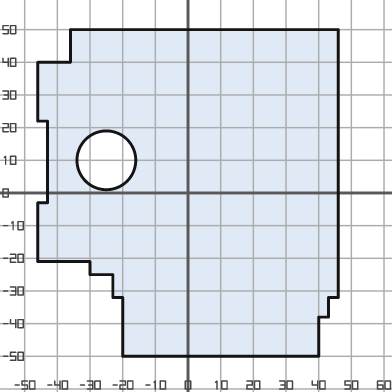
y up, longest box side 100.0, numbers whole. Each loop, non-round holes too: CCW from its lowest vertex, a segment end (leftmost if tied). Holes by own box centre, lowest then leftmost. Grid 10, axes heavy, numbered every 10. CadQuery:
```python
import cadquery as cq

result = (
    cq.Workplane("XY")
    .moveTo(-20.0, -50.0)
    .lineTo(40.0, -50.0)
    .lineTo(40.0, -38.0)
    .lineTo(43.0, -38.0)
    .lineTo(43.0, -32.0)
    .lineTo(46.0, -32.0)
    .lineTo(46.0, 50.0)
    .lineTo(-36.0, 50.0)
    .lineTo(-36.0, 40.0)
    .lineTo(-46.0, 40.0)
    .lineTo(-46.0, 22.0)
    .lineTo(-43.0, 22.0)
    .lineTo(-43.0, -3.0)
    .lineTo(-46.0, -3.0)
    .lineTo(-46.0, -21.0)
    .lineTo(-30.0, -21.0)
    .lineTo(-30.0, -25.0)
    .lineTo(-23.0, -25.0)
    .lineTo(-23.0, -32.0)
    .lineTo(-20.0, -32.0)
    .close()
    .moveTo(-25.0, 10.0)
    .circle(9.0)
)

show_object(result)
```